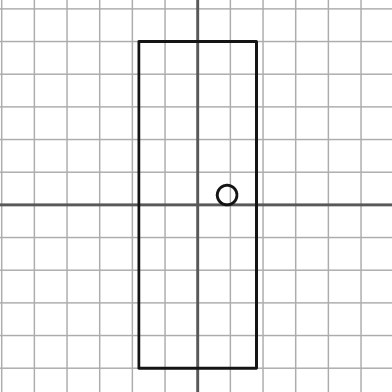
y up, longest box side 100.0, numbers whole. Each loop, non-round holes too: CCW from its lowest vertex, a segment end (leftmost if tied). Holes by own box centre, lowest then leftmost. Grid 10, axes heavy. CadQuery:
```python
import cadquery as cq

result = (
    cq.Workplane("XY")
    .moveTo(-18.0, -50.0)
    .lineTo(18.0, -50.0)
    .lineTo(18.0, 50.0)
    .lineTo(-18.0, 50.0)
    .close()
    .moveTo(9.0, 3.0)
    .circle(3.0)
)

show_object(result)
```